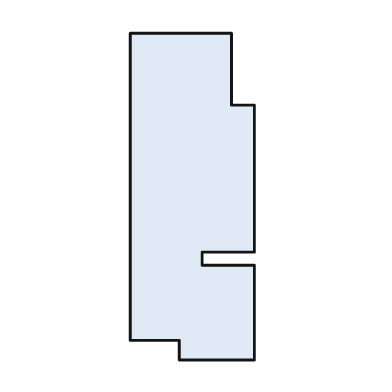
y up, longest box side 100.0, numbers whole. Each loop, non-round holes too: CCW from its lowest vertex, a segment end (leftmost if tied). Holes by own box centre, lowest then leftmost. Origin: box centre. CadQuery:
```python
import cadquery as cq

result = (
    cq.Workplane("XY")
    .moveTo(-4.0, -50.0)
    .lineTo(19.0, -50.0)
    .lineTo(19.0, -21.0)
    .lineTo(3.0, -21.0)
    .lineTo(3.0, -17.0)
    .lineTo(19.0, -17.0)
    .lineTo(19.0, 28.0)
    .lineTo(12.0, 28.0)
    .lineTo(12.0, 50.0)
    .lineTo(-19.0, 50.0)
    .lineTo(-19.0, -44.0)
    .lineTo(-4.0, -44.0)
    .close()
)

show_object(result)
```